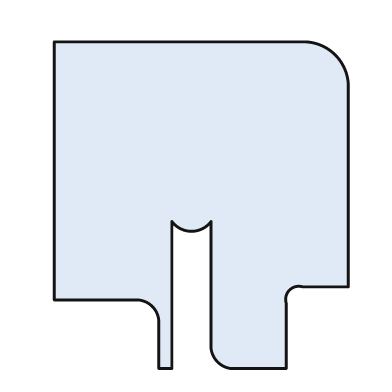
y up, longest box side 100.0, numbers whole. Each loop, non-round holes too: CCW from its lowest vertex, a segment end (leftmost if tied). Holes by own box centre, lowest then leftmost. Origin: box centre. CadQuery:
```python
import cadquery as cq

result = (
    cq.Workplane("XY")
    .moveTo(-13.0, -50.0)
    .lineTo(-9.0, -50.0)
    .lineTo(-9.0, -5.0)
    .threePointArc((-3.0, -8.0), (3.0, -5.0))
    .lineTo(3.0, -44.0)
    .threePointArc((5.0, -48.0), (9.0, -50.0))
    .lineTo(26.0, -50.0)
    .lineTo(26.0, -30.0)
    .threePointArc((27.0, -26.0), (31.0, -25.0))
    .lineTo(45.0, -25.0)
    .lineTo(45.0, 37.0)
    .threePointArc((41.0, 46.0), (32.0, 50.0))
    .lineTo(-45.0, 50.0)
    .lineTo(-45.0, -29.0)
    .lineTo(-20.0, -29.0)
    .threePointArc((-15.0, -31.0), (-13.0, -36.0))
    .close()
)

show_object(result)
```